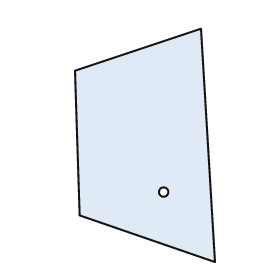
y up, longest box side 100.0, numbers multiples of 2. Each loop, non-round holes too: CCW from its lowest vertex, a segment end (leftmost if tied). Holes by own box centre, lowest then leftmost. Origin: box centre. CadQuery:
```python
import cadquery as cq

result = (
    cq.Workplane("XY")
    .moveTo(30.0, -50.0)
    .lineTo(24.0, 50.0)
    .lineTo(-30.0, 32.0)
    .lineTo(-28.0, -30.0)
    .close()
    .moveTo(8.0, -20.0)
    .circle(2.0)
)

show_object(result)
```